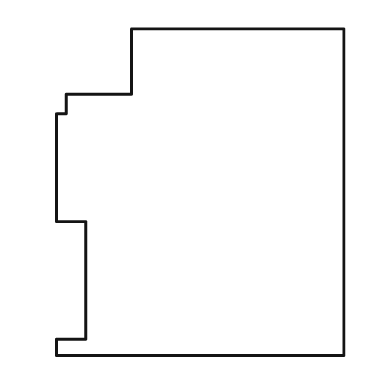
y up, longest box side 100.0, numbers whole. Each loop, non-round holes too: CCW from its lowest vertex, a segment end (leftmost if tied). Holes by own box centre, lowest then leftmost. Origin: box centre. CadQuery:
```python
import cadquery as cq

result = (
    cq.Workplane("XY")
    .moveTo(-44.0, -50.0)
    .lineTo(44.0, -50.0)
    .lineTo(44.0, 50.0)
    .lineTo(-21.0, 50.0)
    .lineTo(-21.0, 30.0)
    .lineTo(-41.0, 30.0)
    .lineTo(-41.0, 24.0)
    .lineTo(-44.0, 24.0)
    .lineTo(-44.0, -9.0)
    .lineTo(-35.0, -9.0)
    .lineTo(-35.0, -45.0)
    .lineTo(-44.0, -45.0)
    .close()
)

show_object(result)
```